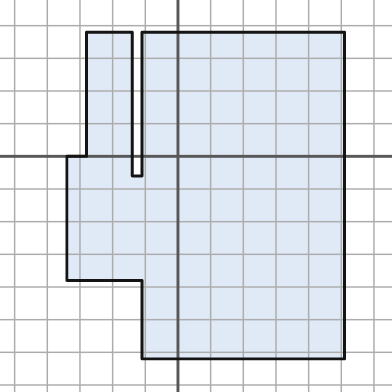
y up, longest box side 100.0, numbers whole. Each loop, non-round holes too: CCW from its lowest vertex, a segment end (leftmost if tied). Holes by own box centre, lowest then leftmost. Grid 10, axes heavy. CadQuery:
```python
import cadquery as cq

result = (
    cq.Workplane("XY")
    .moveTo(-11.0, -62.0)
    .lineTo(51.0, -62.0)
    .lineTo(51.0, 38.0)
    .lineTo(-11.0, 38.0)
    .lineTo(-11.0, -6.0)
    .lineTo(-14.0, -6.0)
    .lineTo(-14.0, 38.0)
    .lineTo(-28.0, 38.0)
    .lineTo(-28.0, 0.0)
    .lineTo(-34.0, 0.0)
    .lineTo(-34.0, -38.0)
    .lineTo(-11.0, -38.0)
    .close()
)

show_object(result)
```